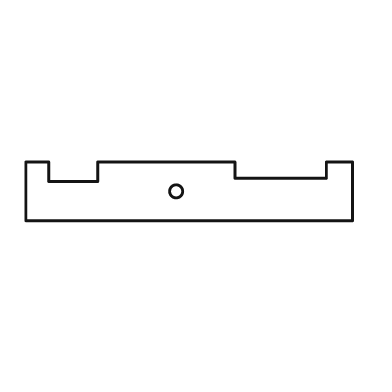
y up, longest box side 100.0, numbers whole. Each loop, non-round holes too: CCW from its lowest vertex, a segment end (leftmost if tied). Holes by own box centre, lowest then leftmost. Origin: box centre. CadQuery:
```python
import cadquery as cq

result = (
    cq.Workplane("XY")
    .moveTo(-50.0, -9.0)
    .lineTo(50.0, -9.0)
    .lineTo(50.0, 9.0)
    .lineTo(42.0, 9.0)
    .lineTo(42.0, 4.0)
    .lineTo(14.0, 4.0)
    .lineTo(14.0, 9.0)
    .lineTo(-28.0, 9.0)
    .lineTo(-28.0, 3.0)
    .lineTo(-43.0, 3.0)
    .lineTo(-43.0, 9.0)
    .lineTo(-50.0, 9.0)
    .close()
    .moveTo(-4.0, 0.0)
    .circle(2.0)
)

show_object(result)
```